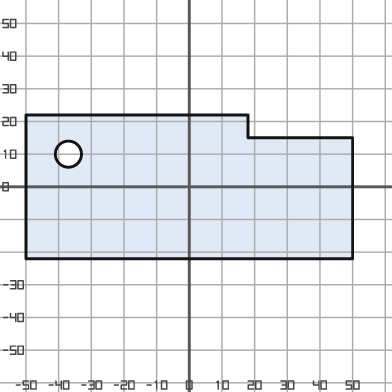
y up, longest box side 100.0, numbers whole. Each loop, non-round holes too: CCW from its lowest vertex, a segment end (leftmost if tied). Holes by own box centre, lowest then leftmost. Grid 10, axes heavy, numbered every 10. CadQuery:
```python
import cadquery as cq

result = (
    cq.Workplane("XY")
    .moveTo(-50.0, -22.0)
    .lineTo(50.0, -22.0)
    .lineTo(50.0, 15.0)
    .lineTo(18.0, 15.0)
    .lineTo(18.0, 22.0)
    .lineTo(-50.0, 22.0)
    .close()
    .moveTo(-37.0, 10.0)
    .circle(4.0)
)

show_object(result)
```